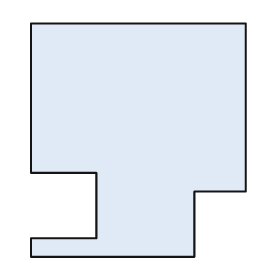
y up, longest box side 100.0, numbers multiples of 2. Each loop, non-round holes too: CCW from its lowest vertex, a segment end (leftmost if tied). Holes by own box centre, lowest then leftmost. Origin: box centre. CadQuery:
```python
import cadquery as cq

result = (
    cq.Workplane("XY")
    .moveTo(-46.0, -50.0)
    .lineTo(24.0, -50.0)
    .lineTo(24.0, -22.0)
    .lineTo(46.0, -22.0)
    .lineTo(46.0, 50.0)
    .lineTo(-46.0, 50.0)
    .lineTo(-46.0, -14.0)
    .lineTo(-18.0, -14.0)
    .lineTo(-18.0, -42.0)
    .lineTo(-46.0, -42.0)
    .close()
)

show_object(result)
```